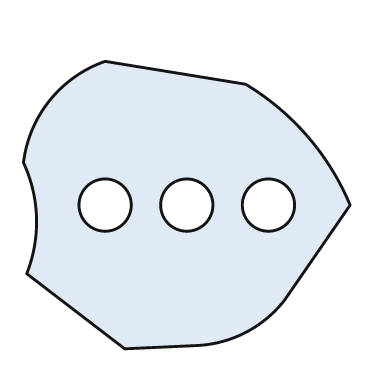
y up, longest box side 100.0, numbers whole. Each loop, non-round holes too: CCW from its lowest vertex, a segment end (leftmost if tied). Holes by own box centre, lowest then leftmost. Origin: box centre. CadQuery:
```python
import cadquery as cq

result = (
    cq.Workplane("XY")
    .moveTo(-19.0, -44.0)
    .lineTo(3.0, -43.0)
    .threePointArc((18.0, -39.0), (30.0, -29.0))
    .lineTo(50.0, 0.0)
    .threePointArc((37.0, 21.0), (18.0, 37.0))
    .lineTo(-25.0, 44.0)
    .threePointArc((-42.0, 32.0), (-50.0, 13.0))
    .threePointArc((-46.0, -4.0), (-49.0, -21.0))
    .close()
    .moveTo(-25.0, 0.0)
    .circle(8.0)
    .moveTo(0.0, 0.0)
    .circle(8.0)
    .moveTo(25.0, 0.0)
    .circle(8.0)
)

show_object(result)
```